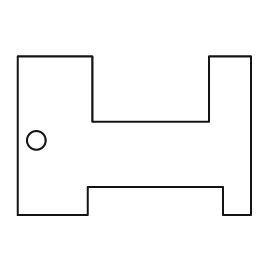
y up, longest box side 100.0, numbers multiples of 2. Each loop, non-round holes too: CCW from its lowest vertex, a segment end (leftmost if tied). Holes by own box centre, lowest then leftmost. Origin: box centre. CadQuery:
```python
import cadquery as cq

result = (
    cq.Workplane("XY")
    .moveTo(-50.0, -34.0)
    .lineTo(-20.0, -34.0)
    .lineTo(-20.0, -22.0)
    .lineTo(38.0, -22.0)
    .lineTo(38.0, -34.0)
    .lineTo(50.0, -34.0)
    .lineTo(50.0, 34.0)
    .lineTo(32.0, 34.0)
    .lineTo(32.0, 6.0)
    .lineTo(-18.0, 6.0)
    .lineTo(-18.0, 34.0)
    .lineTo(-50.0, 34.0)
    .close()
    .moveTo(-42.0, -2.0)
    .circle(4.0)
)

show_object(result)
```